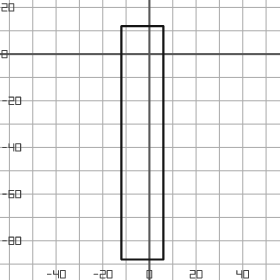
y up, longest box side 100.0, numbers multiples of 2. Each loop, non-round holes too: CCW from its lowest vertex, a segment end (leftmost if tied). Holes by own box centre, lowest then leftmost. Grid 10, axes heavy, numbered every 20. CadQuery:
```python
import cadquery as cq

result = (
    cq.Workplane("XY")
    .moveTo(-12.0, -88.0)
    .lineTo(6.0, -88.0)
    .lineTo(6.0, 12.0)
    .lineTo(-12.0, 12.0)
    .close()
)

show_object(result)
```